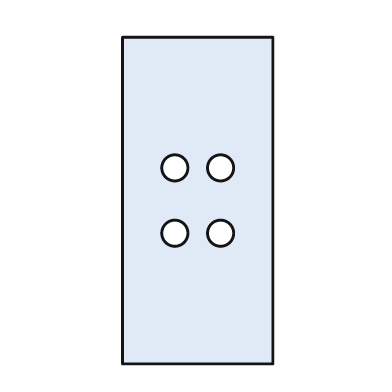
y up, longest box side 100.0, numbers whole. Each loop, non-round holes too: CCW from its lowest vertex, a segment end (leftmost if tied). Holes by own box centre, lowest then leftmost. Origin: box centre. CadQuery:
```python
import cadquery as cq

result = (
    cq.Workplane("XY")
    .moveTo(-23.0, -50.0)
    .lineTo(23.0, -50.0)
    .lineTo(23.0, 50.0)
    .lineTo(-23.0, 50.0)
    .close()
    .moveTo(-7.0, -10.0)
    .circle(4.0)
    .moveTo(7.0, -10.0)
    .circle(4.0)
    .moveTo(-7.0, 10.0)
    .circle(4.0)
    .moveTo(7.0, 10.0)
    .circle(4.0)
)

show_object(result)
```